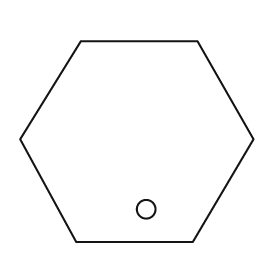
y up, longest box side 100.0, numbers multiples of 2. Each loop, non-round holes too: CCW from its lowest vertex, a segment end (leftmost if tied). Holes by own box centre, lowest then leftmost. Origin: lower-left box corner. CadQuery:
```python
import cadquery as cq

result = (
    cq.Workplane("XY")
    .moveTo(24.0, 0.0)
    .lineTo(74.0, 0.0)
    .lineTo(100.0, 44.0)
    .lineTo(76.0, 86.0)
    .lineTo(26.0, 86.0)
    .lineTo(0.0, 44.0)
    .close()
    .moveTo(54.0, 14.0)
    .circle(4.0)
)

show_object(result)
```